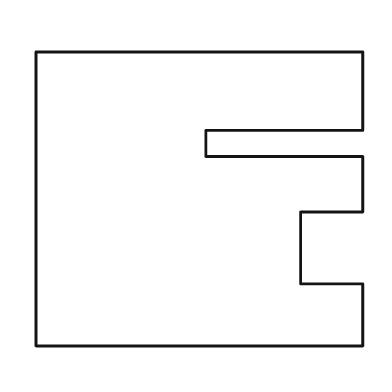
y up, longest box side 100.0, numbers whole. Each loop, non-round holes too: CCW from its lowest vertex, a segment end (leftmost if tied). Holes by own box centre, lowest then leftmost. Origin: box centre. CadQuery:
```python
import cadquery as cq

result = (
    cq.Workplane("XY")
    .moveTo(-50.0, -45.0)
    .lineTo(50.0, -45.0)
    .lineTo(50.0, -26.0)
    .lineTo(31.0, -26.0)
    .lineTo(31.0, -4.0)
    .lineTo(50.0, -4.0)
    .lineTo(50.0, 13.0)
    .lineTo(2.0, 13.0)
    .lineTo(2.0, 21.0)
    .lineTo(50.0, 21.0)
    .lineTo(50.0, 45.0)
    .lineTo(-50.0, 45.0)
    .close()
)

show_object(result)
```